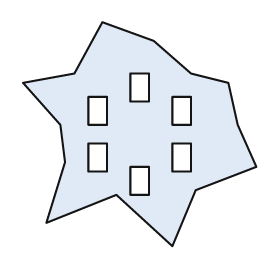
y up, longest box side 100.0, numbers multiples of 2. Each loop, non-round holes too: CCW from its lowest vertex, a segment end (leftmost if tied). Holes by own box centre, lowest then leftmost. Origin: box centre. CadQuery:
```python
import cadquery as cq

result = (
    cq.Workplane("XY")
    .moveTo(14.0, -48.0)
    .lineTo(24.0, -24.0)
    .lineTo(50.0, -14.0)
    .lineTo(42.0, 4.0)
    .lineTo(38.0, 22.0)
    .lineTo(22.0, 26.0)
    .lineTo(6.0, 40.0)
    .lineTo(-16.0, 48.0)
    .lineTo(-28.0, 26.0)
    .lineTo(-50.0, 22.0)
    .lineTo(-34.0, 4.0)
    .lineTo(-32.0, -12.0)
    .lineTo(-40.0, -38.0)
    .lineTo(-10.0, -26.0)
    .close()
    .moveTo(-4.0, -26.0)
    .lineTo(4.0, -26.0)
    .lineTo(4.0, -14.0)
    .lineTo(-4.0, -14.0)
    .close()
    .moveTo(-22.0, -16.0)
    .lineTo(-14.0, -16.0)
    .lineTo(-14.0, -4.0)
    .lineTo(-22.0, -4.0)
    .close()
    .moveTo(14.0, -16.0)
    .lineTo(22.0, -16.0)
    .lineTo(22.0, -4.0)
    .lineTo(14.0, -4.0)
    .close()
    .moveTo(-22.0, 4.0)
    .lineTo(-14.0, 4.0)
    .lineTo(-14.0, 16.0)
    .lineTo(-22.0, 16.0)
    .close()
    .moveTo(14.0, 4.0)
    .lineTo(22.0, 4.0)
    .lineTo(22.0, 16.0)
    .lineTo(14.0, 16.0)
    .close()
    .moveTo(-4.0, 14.0)
    .lineTo(4.0, 14.0)
    .lineTo(4.0, 26.0)
    .lineTo(-4.0, 26.0)
    .close()
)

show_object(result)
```